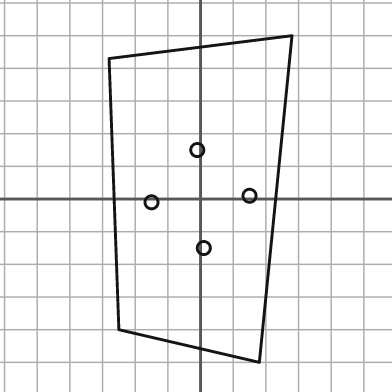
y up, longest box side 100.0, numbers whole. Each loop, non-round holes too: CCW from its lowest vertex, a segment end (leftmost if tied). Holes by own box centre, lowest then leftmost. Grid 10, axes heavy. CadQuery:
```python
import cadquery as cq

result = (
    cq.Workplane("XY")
    .moveTo(18.0, -50.0)
    .lineTo(28.0, 50.0)
    .lineTo(-28.0, 43.0)
    .lineTo(-25.0, -40.0)
    .close()
    .moveTo(1.0, -15.0)
    .circle(2.0)
    .moveTo(-15.0, -1.0)
    .circle(2.0)
    .moveTo(15.0, 1.0)
    .circle(2.0)
    .moveTo(-1.0, 15.0)
    .circle(2.0)
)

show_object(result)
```